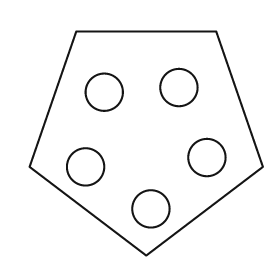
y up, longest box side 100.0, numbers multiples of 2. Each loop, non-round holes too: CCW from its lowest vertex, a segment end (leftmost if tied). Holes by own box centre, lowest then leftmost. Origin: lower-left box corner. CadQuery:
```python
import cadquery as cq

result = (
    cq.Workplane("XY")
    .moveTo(50.0, 0.0)
    .lineTo(100.0, 38.0)
    .lineTo(80.0, 96.0)
    .lineTo(20.0, 96.0)
    .lineTo(0.0, 38.0)
    .close()
    .moveTo(52.0, 20.0)
    .circle(8.0)
    .moveTo(24.0, 38.0)
    .circle(8.0)
    .moveTo(76.0, 42.0)
    .circle(8.0)
    .moveTo(32.0, 70.0)
    .circle(8.0)
    .moveTo(64.0, 72.0)
    .circle(8.0)
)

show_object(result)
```